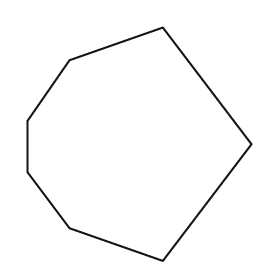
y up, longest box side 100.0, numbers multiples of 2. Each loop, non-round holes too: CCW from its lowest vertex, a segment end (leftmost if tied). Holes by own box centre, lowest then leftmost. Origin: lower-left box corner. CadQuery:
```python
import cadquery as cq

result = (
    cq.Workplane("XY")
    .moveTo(58.0, 0.0)
    .lineTo(96.0, 50.0)
    .lineTo(58.0, 100.0)
    .lineTo(18.0, 86.0)
    .lineTo(0.0, 60.0)
    .lineTo(0.0, 38.0)
    .lineTo(18.0, 14.0)
    .close()
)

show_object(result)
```